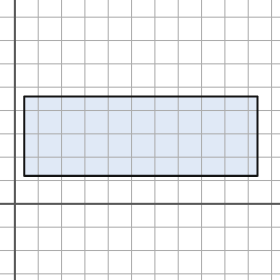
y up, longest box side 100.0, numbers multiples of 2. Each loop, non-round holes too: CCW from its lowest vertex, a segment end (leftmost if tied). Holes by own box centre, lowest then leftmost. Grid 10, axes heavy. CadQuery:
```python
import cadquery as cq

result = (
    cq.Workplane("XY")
    .moveTo(4.0, 12.0)
    .lineTo(104.0, 12.0)
    .lineTo(104.0, 46.0)
    .lineTo(4.0, 46.0)
    .close()
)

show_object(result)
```